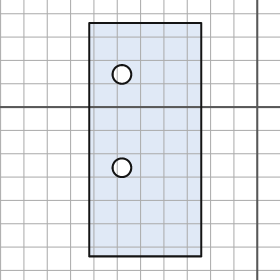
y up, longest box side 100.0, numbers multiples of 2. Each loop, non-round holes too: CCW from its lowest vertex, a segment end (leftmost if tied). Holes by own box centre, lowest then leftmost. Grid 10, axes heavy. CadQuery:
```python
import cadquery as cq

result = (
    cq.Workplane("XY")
    .moveTo(-72.0, -64.0)
    .lineTo(-24.0, -64.0)
    .lineTo(-24.0, 36.0)
    .lineTo(-72.0, 36.0)
    .close()
    .moveTo(-58.0, -26.0)
    .circle(4.0)
    .moveTo(-58.0, 14.0)
    .circle(4.0)
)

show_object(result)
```